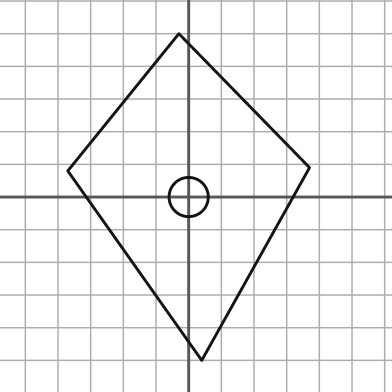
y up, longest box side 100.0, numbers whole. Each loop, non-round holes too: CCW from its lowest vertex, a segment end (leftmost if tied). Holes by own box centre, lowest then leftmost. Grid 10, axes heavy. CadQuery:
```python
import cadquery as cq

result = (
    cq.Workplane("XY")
    .moveTo(4.0, -50.0)
    .lineTo(37.0, 9.0)
    .lineTo(-3.0, 50.0)
    .lineTo(-37.0, 8.0)
    .close()
    .moveTo(0.0, 0.0)
    .circle(6.0)
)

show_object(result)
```